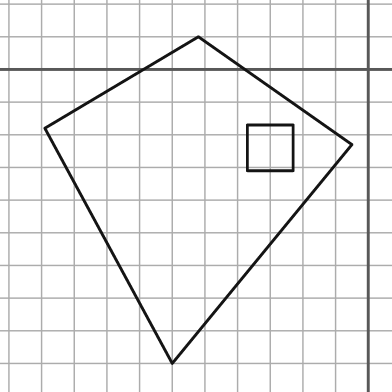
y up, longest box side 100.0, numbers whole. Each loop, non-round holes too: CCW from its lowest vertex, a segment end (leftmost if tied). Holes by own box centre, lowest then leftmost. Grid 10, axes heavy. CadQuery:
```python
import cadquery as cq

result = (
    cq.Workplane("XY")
    .moveTo(-60.0, -90.0)
    .lineTo(-5.0, -23.0)
    .lineTo(-52.0, 10.0)
    .lineTo(-99.0, -18.0)
    .close()
    .moveTo(-37.0, -31.0)
    .lineTo(-23.0, -31.0)
    .lineTo(-23.0, -17.0)
    .lineTo(-37.0, -17.0)
    .close()
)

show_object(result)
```